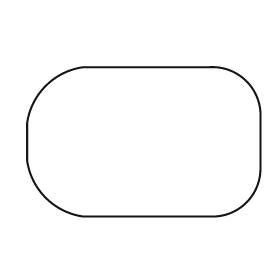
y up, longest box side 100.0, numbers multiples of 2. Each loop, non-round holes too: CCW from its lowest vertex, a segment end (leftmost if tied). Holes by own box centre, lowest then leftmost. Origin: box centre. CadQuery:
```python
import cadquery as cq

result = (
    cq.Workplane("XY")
    .moveTo(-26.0, -32.0)
    .lineTo(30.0, -32.0)
    .threePointArc((44.0, -26.0), (50.0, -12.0))
    .lineTo(50.0, 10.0)
    .threePointArc((44.0, 26.0), (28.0, 32.0))
    .lineTo(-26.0, 32.0)
    .threePointArc((-42.0, 24.0), (-50.0, 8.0))
    .lineTo(-50.0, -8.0)
    .threePointArc((-42.0, -24.0), (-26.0, -32.0))
    .close()
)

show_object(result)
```